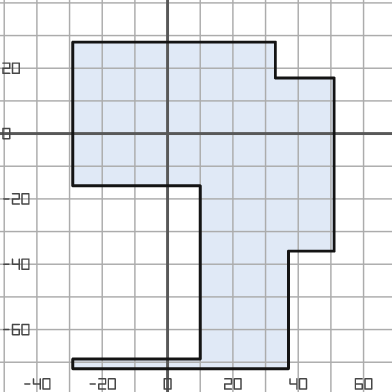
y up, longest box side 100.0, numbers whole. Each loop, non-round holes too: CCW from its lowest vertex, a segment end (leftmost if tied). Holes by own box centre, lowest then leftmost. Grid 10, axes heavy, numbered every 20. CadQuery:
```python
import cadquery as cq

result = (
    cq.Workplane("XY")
    .moveTo(-29.0, -72.0)
    .lineTo(37.0, -72.0)
    .lineTo(37.0, -36.0)
    .lineTo(51.0, -36.0)
    .lineTo(51.0, 17.0)
    .lineTo(33.0, 17.0)
    .lineTo(33.0, 28.0)
    .lineTo(-29.0, 28.0)
    .lineTo(-29.0, -16.0)
    .lineTo(10.0, -16.0)
    .lineTo(10.0, -69.0)
    .lineTo(-29.0, -69.0)
    .close()
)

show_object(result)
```